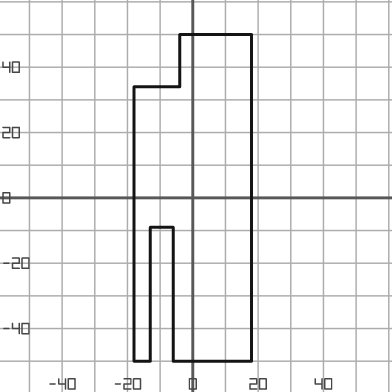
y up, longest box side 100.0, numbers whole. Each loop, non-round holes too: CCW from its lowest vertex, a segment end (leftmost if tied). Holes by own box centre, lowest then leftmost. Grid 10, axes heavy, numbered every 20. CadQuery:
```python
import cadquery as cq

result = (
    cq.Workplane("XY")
    .moveTo(-18.0, -50.0)
    .lineTo(-13.0, -50.0)
    .lineTo(-13.0, -9.0)
    .lineTo(-6.0, -9.0)
    .lineTo(-6.0, -50.0)
    .lineTo(18.0, -50.0)
    .lineTo(18.0, 50.0)
    .lineTo(-4.0, 50.0)
    .lineTo(-4.0, 34.0)
    .lineTo(-18.0, 34.0)
    .close()
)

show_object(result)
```